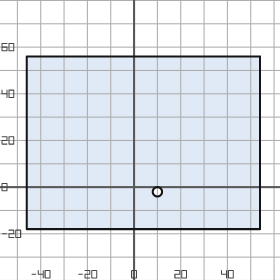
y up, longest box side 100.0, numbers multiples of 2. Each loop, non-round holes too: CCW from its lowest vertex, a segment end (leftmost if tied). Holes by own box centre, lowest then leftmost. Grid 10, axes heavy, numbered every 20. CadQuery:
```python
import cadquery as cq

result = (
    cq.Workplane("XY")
    .moveTo(-46.0, -18.0)
    .lineTo(54.0, -18.0)
    .lineTo(54.0, 56.0)
    .lineTo(-46.0, 56.0)
    .close()
    .moveTo(10.0, -2.0)
    .circle(2.0)
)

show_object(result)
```